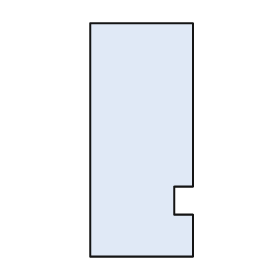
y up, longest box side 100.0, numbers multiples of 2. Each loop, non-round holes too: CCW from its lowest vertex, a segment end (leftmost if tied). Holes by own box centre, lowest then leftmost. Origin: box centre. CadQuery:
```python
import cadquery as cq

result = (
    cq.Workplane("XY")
    .moveTo(-22.0, -50.0)
    .lineTo(22.0, -50.0)
    .lineTo(22.0, -32.0)
    .lineTo(14.0, -32.0)
    .lineTo(14.0, -20.0)
    .lineTo(22.0, -20.0)
    .lineTo(22.0, 50.0)
    .lineTo(-22.0, 50.0)
    .close()
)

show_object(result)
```